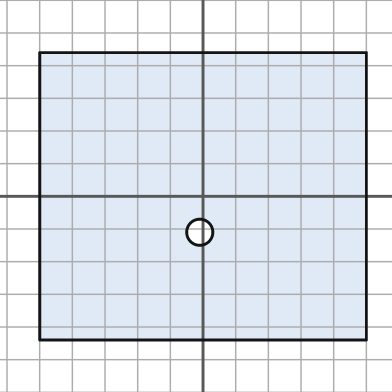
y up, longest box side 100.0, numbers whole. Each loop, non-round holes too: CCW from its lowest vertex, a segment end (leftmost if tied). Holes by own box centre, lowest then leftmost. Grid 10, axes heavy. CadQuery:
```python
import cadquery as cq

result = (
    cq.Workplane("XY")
    .moveTo(-50.0, -44.0)
    .lineTo(50.0, -44.0)
    .lineTo(50.0, 44.0)
    .lineTo(-50.0, 44.0)
    .close()
    .moveTo(-1.0, -11.0)
    .circle(4.0)
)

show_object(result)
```